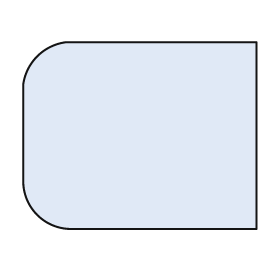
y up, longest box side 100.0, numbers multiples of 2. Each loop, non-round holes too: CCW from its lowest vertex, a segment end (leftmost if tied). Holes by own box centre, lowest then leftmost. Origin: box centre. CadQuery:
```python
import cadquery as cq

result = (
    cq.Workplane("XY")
    .moveTo(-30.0, -40.0)
    .lineTo(50.0, -40.0)
    .lineTo(50.0, 40.0)
    .lineTo(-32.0, 40.0)
    .threePointArc((-44.0, 34.0), (-50.0, 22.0))
    .lineTo(-50.0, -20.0)
    .threePointArc((-44.0, -34.0), (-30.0, -40.0))
    .close()
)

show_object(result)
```